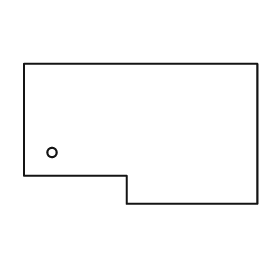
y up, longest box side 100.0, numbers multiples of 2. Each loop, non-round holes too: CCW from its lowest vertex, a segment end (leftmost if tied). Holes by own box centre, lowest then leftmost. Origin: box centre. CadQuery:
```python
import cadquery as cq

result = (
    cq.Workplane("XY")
    .moveTo(-6.0, -30.0)
    .lineTo(50.0, -30.0)
    .lineTo(50.0, 30.0)
    .lineTo(-50.0, 30.0)
    .lineTo(-50.0, -18.0)
    .lineTo(-6.0, -18.0)
    .close()
    .moveTo(-38.0, -8.0)
    .circle(2.0)
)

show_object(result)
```